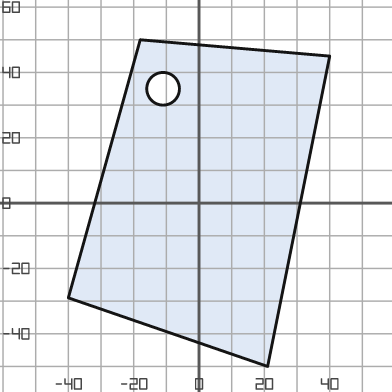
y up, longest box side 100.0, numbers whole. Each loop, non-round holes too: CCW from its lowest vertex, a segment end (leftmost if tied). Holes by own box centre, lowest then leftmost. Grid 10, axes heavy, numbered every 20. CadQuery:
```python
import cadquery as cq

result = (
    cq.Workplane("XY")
    .moveTo(21.0, -50.0)
    .lineTo(40.0, 45.0)
    .lineTo(-18.0, 50.0)
    .lineTo(-40.0, -29.0)
    .close()
    .moveTo(-11.0, 35.0)
    .circle(5.0)
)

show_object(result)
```